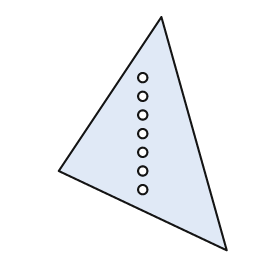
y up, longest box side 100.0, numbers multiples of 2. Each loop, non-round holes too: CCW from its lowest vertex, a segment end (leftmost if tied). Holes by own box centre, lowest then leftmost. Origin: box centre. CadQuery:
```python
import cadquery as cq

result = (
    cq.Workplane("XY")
    .moveTo(36.0, -50.0)
    .lineTo(8.0, 50.0)
    .lineTo(-36.0, -16.0)
    .close()
    .moveTo(0.0, -24.0)
    .circle(2.0)
    .moveTo(0.0, -16.0)
    .circle(2.0)
    .moveTo(0.0, -8.0)
    .circle(2.0)
    .moveTo(0.0, 0.0)
    .circle(2.0)
    .moveTo(0.0, 8.0)
    .circle(2.0)
    .moveTo(0.0, 16.0)
    .circle(2.0)
    .moveTo(0.0, 24.0)
    .circle(2.0)
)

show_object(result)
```